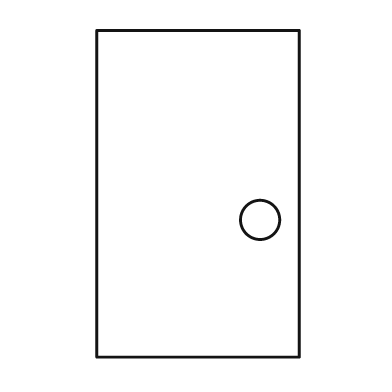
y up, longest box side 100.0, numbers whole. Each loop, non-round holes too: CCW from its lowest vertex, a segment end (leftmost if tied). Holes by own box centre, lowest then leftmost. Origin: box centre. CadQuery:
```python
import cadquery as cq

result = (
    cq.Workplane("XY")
    .moveTo(-31.0, -50.0)
    .lineTo(31.0, -50.0)
    .lineTo(31.0, 50.0)
    .lineTo(-31.0, 50.0)
    .close()
    .moveTo(19.0, -8.0)
    .circle(6.0)
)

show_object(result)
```